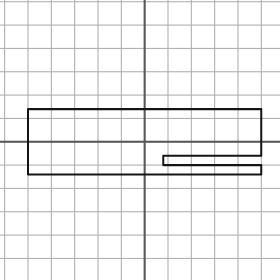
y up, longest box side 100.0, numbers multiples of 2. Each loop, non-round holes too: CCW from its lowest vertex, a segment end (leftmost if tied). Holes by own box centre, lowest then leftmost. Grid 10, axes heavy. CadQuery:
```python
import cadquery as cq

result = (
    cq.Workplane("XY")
    .moveTo(-50.0, -14.0)
    .lineTo(50.0, -14.0)
    .lineTo(50.0, -10.0)
    .lineTo(8.0, -10.0)
    .lineTo(8.0, -6.0)
    .lineTo(50.0, -6.0)
    .lineTo(50.0, 14.0)
    .lineTo(-50.0, 14.0)
    .close()
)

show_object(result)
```